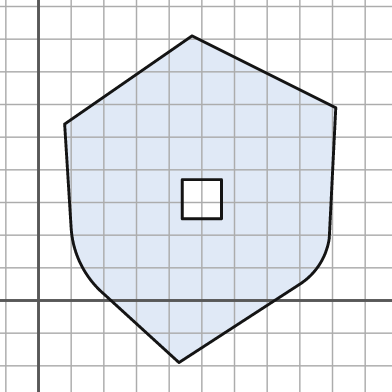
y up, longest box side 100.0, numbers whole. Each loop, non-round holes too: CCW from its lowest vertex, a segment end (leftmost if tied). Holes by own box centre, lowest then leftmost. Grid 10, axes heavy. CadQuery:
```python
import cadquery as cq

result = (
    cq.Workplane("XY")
    .moveTo(43.0, -19.0)
    .lineTo(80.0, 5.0)
    .threePointArc((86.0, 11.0), (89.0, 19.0))
    .lineTo(91.0, 59.0)
    .lineTo(47.0, 81.0)
    .lineTo(8.0, 54.0)
    .lineTo(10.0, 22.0)
    .threePointArc((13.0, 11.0), (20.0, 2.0))
    .close()
    .moveTo(44.0, 25.0)
    .lineTo(56.0, 25.0)
    .lineTo(56.0, 37.0)
    .lineTo(44.0, 37.0)
    .close()
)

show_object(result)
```